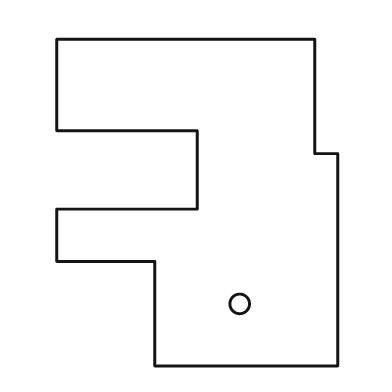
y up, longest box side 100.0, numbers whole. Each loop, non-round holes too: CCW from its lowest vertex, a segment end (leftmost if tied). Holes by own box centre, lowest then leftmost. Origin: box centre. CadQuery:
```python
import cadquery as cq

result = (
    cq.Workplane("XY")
    .moveTo(-13.0, -50.0)
    .lineTo(43.0, -50.0)
    .lineTo(43.0, 15.0)
    .lineTo(36.0, 15.0)
    .lineTo(36.0, 50.0)
    .lineTo(-43.0, 50.0)
    .lineTo(-43.0, 22.0)
    .lineTo(0.0, 22.0)
    .lineTo(0.0, -2.0)
    .lineTo(-43.0, -2.0)
    .lineTo(-43.0, -18.0)
    .lineTo(-13.0, -18.0)
    .close()
    .moveTo(13.0, -31.0)
    .circle(3.0)
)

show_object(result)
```